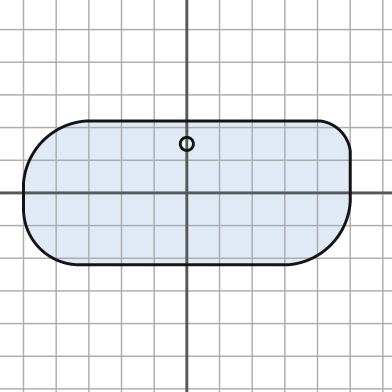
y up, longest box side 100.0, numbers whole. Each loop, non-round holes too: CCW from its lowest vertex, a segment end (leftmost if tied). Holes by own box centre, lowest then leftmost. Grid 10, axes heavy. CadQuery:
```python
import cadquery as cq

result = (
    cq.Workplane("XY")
    .moveTo(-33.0, -22.0)
    .lineTo(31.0, -22.0)
    .threePointArc((44.0, -16.0), (50.0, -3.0))
    .lineTo(50.0, 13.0)
    .threePointArc((47.0, 19.0), (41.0, 22.0))
    .lineTo(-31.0, 22.0)
    .threePointArc((-44.0, 16.0), (-50.0, 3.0))
    .lineTo(-50.0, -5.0)
    .threePointArc((-45.0, -17.0), (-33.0, -22.0))
    .close()
    .moveTo(0.0, 15.0)
    .circle(2.0)
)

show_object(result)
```